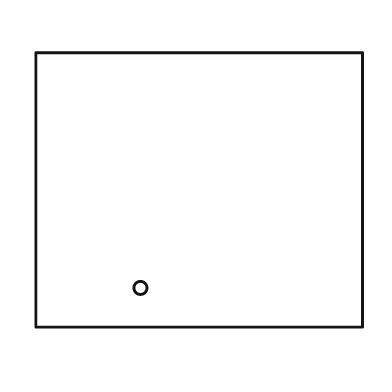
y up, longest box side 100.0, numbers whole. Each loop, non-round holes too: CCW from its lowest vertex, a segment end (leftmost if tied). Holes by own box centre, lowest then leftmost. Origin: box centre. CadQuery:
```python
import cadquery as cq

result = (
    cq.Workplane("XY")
    .moveTo(-50.0, -42.0)
    .lineTo(50.0, -42.0)
    .lineTo(50.0, 42.0)
    .lineTo(-50.0, 42.0)
    .close()
    .moveTo(-18.0, -30.0)
    .circle(2.0)
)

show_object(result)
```